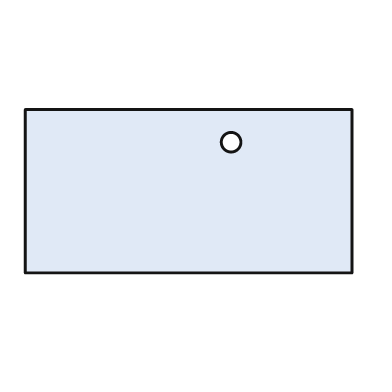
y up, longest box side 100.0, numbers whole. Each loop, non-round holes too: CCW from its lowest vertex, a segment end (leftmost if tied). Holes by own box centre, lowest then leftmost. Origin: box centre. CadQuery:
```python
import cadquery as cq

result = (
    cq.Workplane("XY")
    .moveTo(-50.0, -25.0)
    .lineTo(50.0, -25.0)
    .lineTo(50.0, 25.0)
    .lineTo(-50.0, 25.0)
    .close()
    .moveTo(13.0, 15.0)
    .circle(3.0)
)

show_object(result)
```